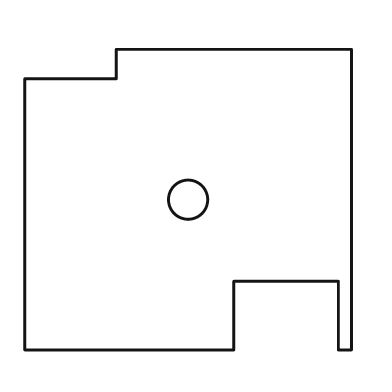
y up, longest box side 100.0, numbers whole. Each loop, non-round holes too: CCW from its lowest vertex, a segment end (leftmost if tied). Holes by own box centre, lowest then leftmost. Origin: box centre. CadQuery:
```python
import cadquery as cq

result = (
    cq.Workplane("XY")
    .moveTo(-50.0, -46.0)
    .lineTo(14.0, -46.0)
    .lineTo(14.0, -25.0)
    .lineTo(46.0, -25.0)
    .lineTo(46.0, -46.0)
    .lineTo(50.0, -46.0)
    .lineTo(50.0, 46.0)
    .lineTo(-22.0, 46.0)
    .lineTo(-22.0, 37.0)
    .lineTo(-50.0, 37.0)
    .close()
    .moveTo(0.0, 0.0)
    .circle(6.0)
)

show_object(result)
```